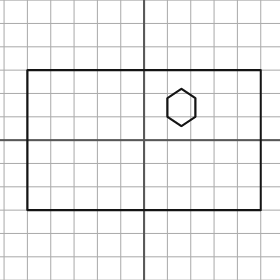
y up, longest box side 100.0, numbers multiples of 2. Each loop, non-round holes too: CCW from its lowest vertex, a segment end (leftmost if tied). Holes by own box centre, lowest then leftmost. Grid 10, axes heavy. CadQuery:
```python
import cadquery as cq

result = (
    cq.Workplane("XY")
    .moveTo(-50.0, -30.0)
    .lineTo(50.0, -30.0)
    .lineTo(50.0, 30.0)
    .lineTo(-50.0, 30.0)
    .close()
    .moveTo(16.0, 6.0)
    .lineTo(22.0, 10.0)
    .lineTo(22.0, 18.0)
    .lineTo(16.0, 22.0)
    .lineTo(10.0, 18.0)
    .lineTo(10.0, 10.0)
    .close()
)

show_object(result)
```